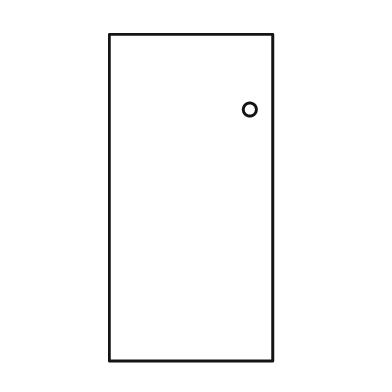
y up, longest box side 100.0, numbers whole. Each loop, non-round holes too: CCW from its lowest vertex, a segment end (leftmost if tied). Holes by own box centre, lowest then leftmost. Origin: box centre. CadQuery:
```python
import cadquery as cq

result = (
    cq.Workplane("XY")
    .moveTo(-25.0, -50.0)
    .lineTo(25.0, -50.0)
    .lineTo(25.0, 50.0)
    .lineTo(-25.0, 50.0)
    .close()
    .moveTo(18.0, 27.0)
    .circle(2.0)
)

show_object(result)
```